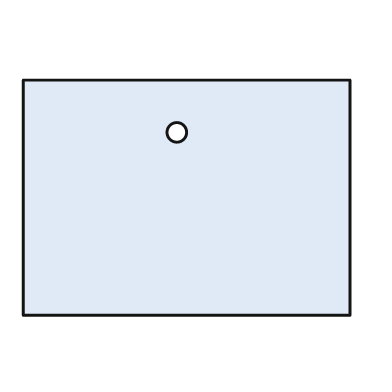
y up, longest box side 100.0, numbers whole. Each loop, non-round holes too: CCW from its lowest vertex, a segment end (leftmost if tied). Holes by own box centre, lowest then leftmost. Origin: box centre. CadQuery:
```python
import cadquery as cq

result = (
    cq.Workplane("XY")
    .moveTo(-50.0, -36.0)
    .lineTo(50.0, -36.0)
    .lineTo(50.0, 36.0)
    .lineTo(-50.0, 36.0)
    .close()
    .moveTo(-3.0, 20.0)
    .circle(3.0)
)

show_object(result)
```